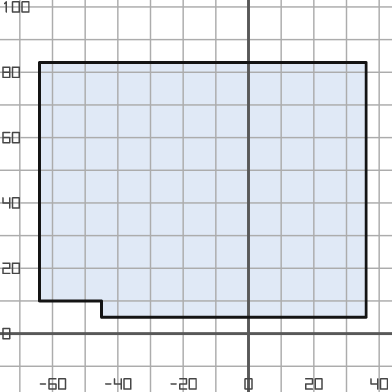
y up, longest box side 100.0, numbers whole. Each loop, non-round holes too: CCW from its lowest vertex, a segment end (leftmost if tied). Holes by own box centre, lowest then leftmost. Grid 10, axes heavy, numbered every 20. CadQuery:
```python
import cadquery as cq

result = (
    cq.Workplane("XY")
    .moveTo(-45.0, 5.0)
    .lineTo(36.0, 5.0)
    .lineTo(36.0, 83.0)
    .lineTo(-64.0, 83.0)
    .lineTo(-64.0, 10.0)
    .lineTo(-45.0, 10.0)
    .close()
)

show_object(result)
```